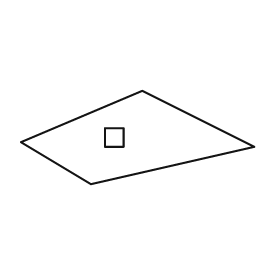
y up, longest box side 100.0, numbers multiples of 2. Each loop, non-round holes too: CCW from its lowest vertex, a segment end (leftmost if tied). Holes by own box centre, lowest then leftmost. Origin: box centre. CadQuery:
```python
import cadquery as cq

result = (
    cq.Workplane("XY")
    .moveTo(-20.0, -20.0)
    .lineTo(50.0, -4.0)
    .lineTo(2.0, 20.0)
    .lineTo(-50.0, -2.0)
    .close()
    .moveTo(-14.0, -4.0)
    .lineTo(-6.0, -4.0)
    .lineTo(-6.0, 4.0)
    .lineTo(-14.0, 4.0)
    .close()
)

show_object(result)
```